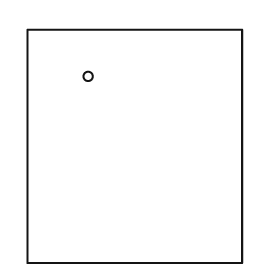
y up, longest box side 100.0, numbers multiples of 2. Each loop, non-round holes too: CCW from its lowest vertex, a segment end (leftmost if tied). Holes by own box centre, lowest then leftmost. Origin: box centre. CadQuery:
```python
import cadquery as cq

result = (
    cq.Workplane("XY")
    .moveTo(-46.0, -50.0)
    .lineTo(46.0, -50.0)
    .lineTo(46.0, 50.0)
    .lineTo(-46.0, 50.0)
    .close()
    .moveTo(-20.0, 30.0)
    .circle(2.0)
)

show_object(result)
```